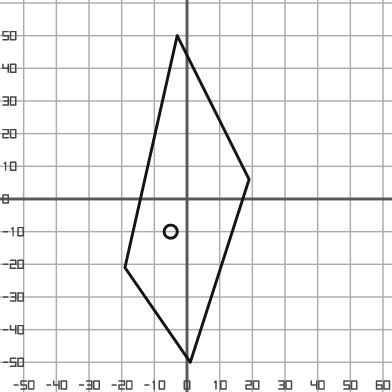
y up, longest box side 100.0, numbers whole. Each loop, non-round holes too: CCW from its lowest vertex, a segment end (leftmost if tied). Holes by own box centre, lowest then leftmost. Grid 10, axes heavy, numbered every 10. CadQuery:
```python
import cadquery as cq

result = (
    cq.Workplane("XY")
    .moveTo(1.0, -50.0)
    .lineTo(19.0, 6.0)
    .lineTo(-3.0, 50.0)
    .lineTo(-19.0, -21.0)
    .close()
    .moveTo(-5.0, -10.0)
    .circle(2.0)
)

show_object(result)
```